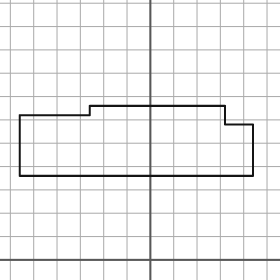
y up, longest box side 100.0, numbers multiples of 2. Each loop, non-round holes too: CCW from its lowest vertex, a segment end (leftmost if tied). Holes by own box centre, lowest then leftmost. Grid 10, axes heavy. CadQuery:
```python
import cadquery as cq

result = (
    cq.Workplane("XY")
    .moveTo(-56.0, 36.0)
    .lineTo(44.0, 36.0)
    .lineTo(44.0, 58.0)
    .lineTo(32.0, 58.0)
    .lineTo(32.0, 66.0)
    .lineTo(-26.0, 66.0)
    .lineTo(-26.0, 62.0)
    .lineTo(-56.0, 62.0)
    .close()
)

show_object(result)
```